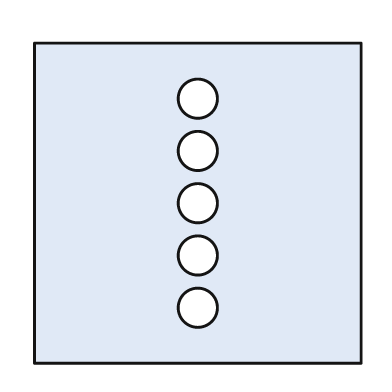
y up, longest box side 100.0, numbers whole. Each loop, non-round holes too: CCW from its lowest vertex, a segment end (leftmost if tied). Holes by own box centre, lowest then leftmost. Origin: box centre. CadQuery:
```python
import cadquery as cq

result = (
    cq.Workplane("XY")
    .moveTo(-50.0, -49.0)
    .lineTo(50.0, -49.0)
    .lineTo(50.0, 49.0)
    .lineTo(-50.0, 49.0)
    .close()
    .moveTo(0.0, -32.0)
    .circle(6.0)
    .moveTo(0.0, -16.0)
    .circle(6.0)
    .moveTo(0.0, 0.0)
    .circle(6.0)
    .moveTo(0.0, 16.0)
    .circle(6.0)
    .moveTo(0.0, 32.0)
    .circle(6.0)
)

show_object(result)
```